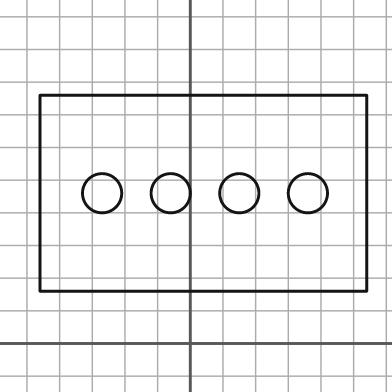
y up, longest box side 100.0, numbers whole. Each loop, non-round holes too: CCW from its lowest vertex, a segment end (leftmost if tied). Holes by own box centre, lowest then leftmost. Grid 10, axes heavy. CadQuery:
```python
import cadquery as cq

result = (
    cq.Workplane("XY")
    .moveTo(-46.0, 16.0)
    .lineTo(54.0, 16.0)
    .lineTo(54.0, 76.0)
    .lineTo(-46.0, 76.0)
    .close()
    .moveTo(-27.0, 46.0)
    .circle(6.0)
    .moveTo(-6.0, 46.0)
    .circle(6.0)
    .moveTo(15.0, 46.0)
    .circle(6.0)
    .moveTo(36.0, 46.0)
    .circle(6.0)
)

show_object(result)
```